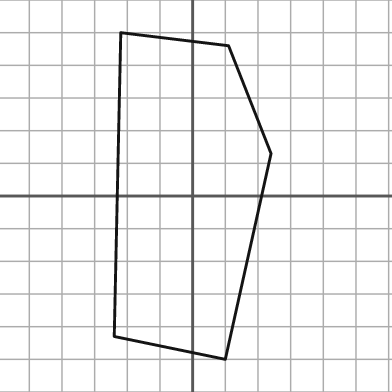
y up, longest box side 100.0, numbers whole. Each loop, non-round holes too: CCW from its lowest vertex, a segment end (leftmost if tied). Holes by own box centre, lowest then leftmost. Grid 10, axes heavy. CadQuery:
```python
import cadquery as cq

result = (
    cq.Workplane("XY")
    .moveTo(10.0, -50.0)
    .lineTo(24.0, 13.0)
    .lineTo(11.0, 46.0)
    .lineTo(-22.0, 50.0)
    .lineTo(-24.0, -43.0)
    .close()
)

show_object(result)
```